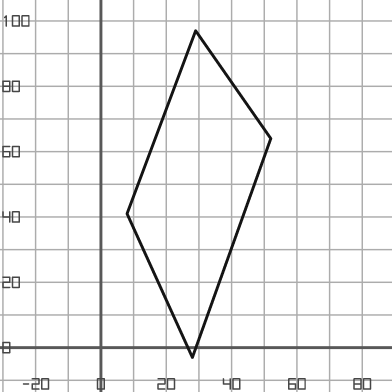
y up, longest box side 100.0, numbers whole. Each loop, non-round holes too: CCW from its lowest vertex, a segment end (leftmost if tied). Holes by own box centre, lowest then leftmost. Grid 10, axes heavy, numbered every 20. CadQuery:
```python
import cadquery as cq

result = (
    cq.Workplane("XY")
    .moveTo(28.0, -3.0)
    .lineTo(52.0, 64.0)
    .lineTo(29.0, 97.0)
    .lineTo(8.0, 41.0)
    .close()
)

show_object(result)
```